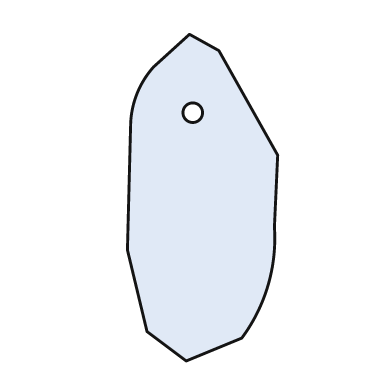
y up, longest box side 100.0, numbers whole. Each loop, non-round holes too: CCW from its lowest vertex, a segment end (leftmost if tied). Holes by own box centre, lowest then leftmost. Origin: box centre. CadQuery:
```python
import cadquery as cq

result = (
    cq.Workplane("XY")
    .moveTo(-5.0, -50.0)
    .lineTo(12.0, -43.0)
    .threePointArc((20.0, -27.0), (22.0, -9.0))
    .lineTo(23.0, 13.0)
    .lineTo(5.0, 45.0)
    .lineTo(-4.0, 50.0)
    .lineTo(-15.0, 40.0)
    .threePointArc((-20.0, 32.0), (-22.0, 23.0))
    .lineTo(-23.0, -16.0)
    .lineTo(-17.0, -41.0)
    .close()
    .moveTo(-3.0, 26.0)
    .circle(3.0)
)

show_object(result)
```